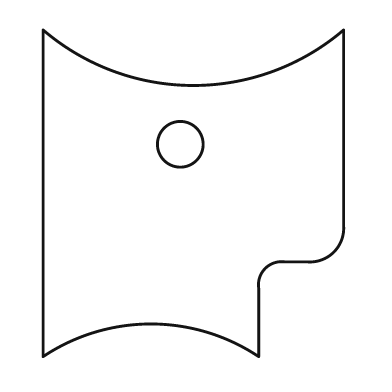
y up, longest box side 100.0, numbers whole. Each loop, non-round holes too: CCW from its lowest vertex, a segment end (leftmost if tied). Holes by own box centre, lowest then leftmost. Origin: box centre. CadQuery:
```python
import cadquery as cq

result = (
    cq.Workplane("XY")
    .moveTo(-46.0, -50.0)
    .threePointArc((-13.0, -40.0), (20.0, -50.0))
    .lineTo(20.0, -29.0)
    .threePointArc((22.0, -23.0), (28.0, -21.0))
    .lineTo(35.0, -21.0)
    .threePointArc((43.0, -18.0), (46.0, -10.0))
    .lineTo(46.0, 50.0)
    .threePointArc((0.0, 33.0), (-46.0, 50.0))
    .close()
    .moveTo(-4.0, 15.0)
    .circle(7.0)
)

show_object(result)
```